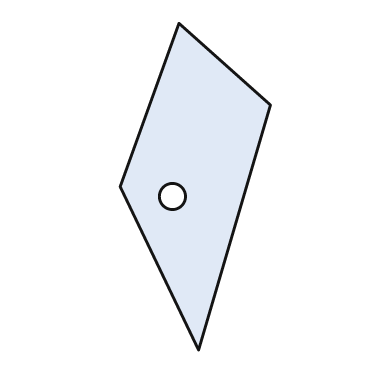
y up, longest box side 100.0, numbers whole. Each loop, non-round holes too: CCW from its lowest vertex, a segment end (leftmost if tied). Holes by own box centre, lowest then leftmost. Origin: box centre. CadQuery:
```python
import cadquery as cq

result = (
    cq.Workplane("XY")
    .moveTo(1.0, -50.0)
    .lineTo(23.0, 25.0)
    .lineTo(-5.0, 50.0)
    .lineTo(-23.0, 0.0)
    .close()
    .moveTo(-7.0, -3.0)
    .circle(4.0)
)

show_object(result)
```